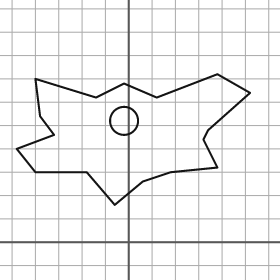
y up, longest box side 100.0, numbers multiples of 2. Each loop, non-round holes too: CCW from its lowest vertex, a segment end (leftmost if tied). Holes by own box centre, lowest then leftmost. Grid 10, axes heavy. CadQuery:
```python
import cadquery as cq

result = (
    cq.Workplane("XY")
    .moveTo(-6.0, 16.0)
    .lineTo(6.0, 26.0)
    .lineTo(18.0, 30.0)
    .lineTo(38.0, 32.0)
    .lineTo(32.0, 44.0)
    .lineTo(34.0, 48.0)
    .lineTo(52.0, 64.0)
    .lineTo(38.0, 72.0)
    .lineTo(12.0, 62.0)
    .lineTo(-2.0, 68.0)
    .lineTo(-14.0, 62.0)
    .lineTo(-40.0, 70.0)
    .lineTo(-38.0, 54.0)
    .lineTo(-32.0, 46.0)
    .lineTo(-48.0, 40.0)
    .lineTo(-40.0, 30.0)
    .lineTo(-18.0, 30.0)
    .close()
    .moveTo(-2.0, 52.0)
    .circle(6.0)
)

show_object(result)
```